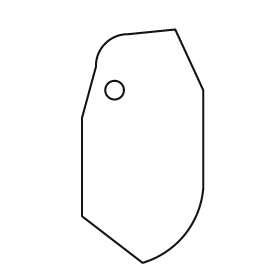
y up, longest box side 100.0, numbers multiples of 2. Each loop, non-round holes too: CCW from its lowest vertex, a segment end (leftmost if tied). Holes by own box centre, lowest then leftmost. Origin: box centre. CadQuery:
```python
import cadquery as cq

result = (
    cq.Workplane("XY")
    .moveTo(0.0, -50.0)
    .threePointArc((18.0, -38.0), (26.0, -18.0))
    .lineTo(26.0, 24.0)
    .lineTo(14.0, 50.0)
    .lineTo(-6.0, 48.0)
    .threePointArc((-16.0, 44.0), (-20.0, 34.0))
    .lineTo(-26.0, 12.0)
    .lineTo(-26.0, -30.0)
    .close()
    .moveTo(-12.0, 24.0)
    .circle(4.0)
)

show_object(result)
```